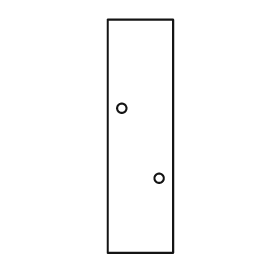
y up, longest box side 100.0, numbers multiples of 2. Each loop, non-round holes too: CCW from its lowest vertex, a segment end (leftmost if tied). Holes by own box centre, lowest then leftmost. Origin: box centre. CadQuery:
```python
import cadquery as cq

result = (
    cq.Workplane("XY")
    .moveTo(-14.0, -50.0)
    .lineTo(14.0, -50.0)
    .lineTo(14.0, 50.0)
    .lineTo(-14.0, 50.0)
    .close()
    .moveTo(8.0, -18.0)
    .circle(2.0)
    .moveTo(-8.0, 12.0)
    .circle(2.0)
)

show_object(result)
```